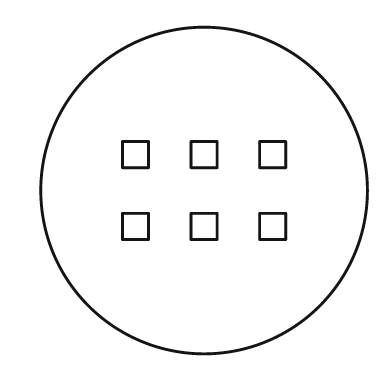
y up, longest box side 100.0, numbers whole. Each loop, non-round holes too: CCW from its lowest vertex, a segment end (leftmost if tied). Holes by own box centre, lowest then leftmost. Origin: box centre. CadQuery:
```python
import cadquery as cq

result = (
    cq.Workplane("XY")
    .moveTo(0.0, 0.0)
    .circle(50.0)
    .moveTo(-25.0, -15.0)
    .lineTo(-17.0, -15.0)
    .lineTo(-17.0, -7.0)
    .lineTo(-25.0, -7.0)
    .close()
    .moveTo(-4.0, -15.0)
    .lineTo(4.0, -15.0)
    .lineTo(4.0, -7.0)
    .lineTo(-4.0, -7.0)
    .close()
    .moveTo(17.0, -15.0)
    .lineTo(25.0, -15.0)
    .lineTo(25.0, -7.0)
    .lineTo(17.0, -7.0)
    .close()
    .moveTo(-25.0, 7.0)
    .lineTo(-17.0, 7.0)
    .lineTo(-17.0, 15.0)
    .lineTo(-25.0, 15.0)
    .close()
    .moveTo(-4.0, 7.0)
    .lineTo(4.0, 7.0)
    .lineTo(4.0, 15.0)
    .lineTo(-4.0, 15.0)
    .close()
    .moveTo(17.0, 7.0)
    .lineTo(25.0, 7.0)
    .lineTo(25.0, 15.0)
    .lineTo(17.0, 15.0)
    .close()
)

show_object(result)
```